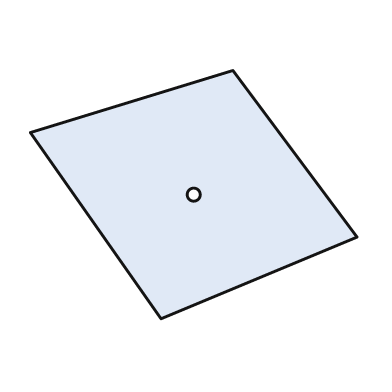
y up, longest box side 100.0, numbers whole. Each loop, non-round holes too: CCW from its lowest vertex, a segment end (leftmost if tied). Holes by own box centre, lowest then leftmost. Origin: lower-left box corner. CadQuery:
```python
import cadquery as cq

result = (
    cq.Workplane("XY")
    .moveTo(40.0, 0.0)
    .lineTo(100.0, 25.0)
    .lineTo(62.0, 76.0)
    .lineTo(0.0, 57.0)
    .close()
    .moveTo(50.0, 38.0)
    .circle(2.0)
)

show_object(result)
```